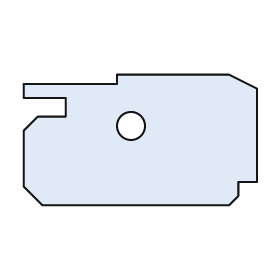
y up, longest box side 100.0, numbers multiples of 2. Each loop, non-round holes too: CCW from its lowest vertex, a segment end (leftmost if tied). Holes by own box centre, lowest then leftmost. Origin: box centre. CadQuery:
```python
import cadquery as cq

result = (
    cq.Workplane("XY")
    .moveTo(-42.0, -28.0)
    .lineTo(38.0, -28.0)
    .lineTo(42.0, -24.0)
    .lineTo(42.0, -18.0)
    .lineTo(50.0, -18.0)
    .lineTo(50.0, 22.0)
    .lineTo(38.0, 28.0)
    .lineTo(-10.0, 28.0)
    .lineTo(-10.0, 24.0)
    .lineTo(-50.0, 24.0)
    .lineTo(-50.0, 18.0)
    .lineTo(-32.0, 18.0)
    .lineTo(-32.0, 10.0)
    .lineTo(-44.0, 10.0)
    .lineTo(-50.0, 4.0)
    .lineTo(-50.0, -20.0)
    .close()
    .moveTo(-4.0, 6.0)
    .circle(6.0)
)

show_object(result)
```